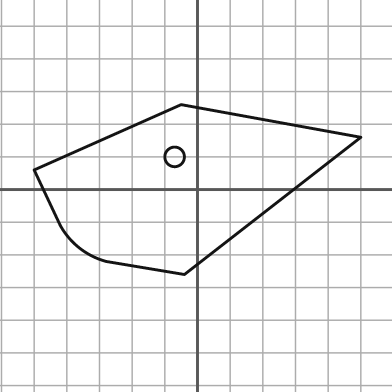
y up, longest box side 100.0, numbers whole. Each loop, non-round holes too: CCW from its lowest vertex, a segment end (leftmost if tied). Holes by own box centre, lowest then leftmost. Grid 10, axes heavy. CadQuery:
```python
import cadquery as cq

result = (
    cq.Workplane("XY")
    .moveTo(-4.0, -26.0)
    .lineTo(50.0, 16.0)
    .lineTo(-5.0, 26.0)
    .lineTo(-50.0, 6.0)
    .lineTo(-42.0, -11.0)
    .threePointArc((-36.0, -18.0), (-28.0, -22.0))
    .close()
    .moveTo(-7.0, 10.0)
    .circle(3.0)
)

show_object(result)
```